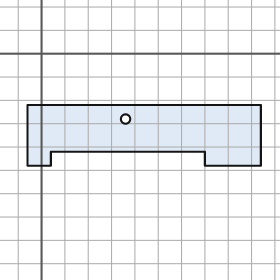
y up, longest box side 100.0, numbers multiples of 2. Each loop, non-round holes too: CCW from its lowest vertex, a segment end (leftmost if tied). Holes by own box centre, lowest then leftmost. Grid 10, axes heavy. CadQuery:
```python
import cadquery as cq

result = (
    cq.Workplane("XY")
    .moveTo(-6.0, -48.0)
    .lineTo(4.0, -48.0)
    .lineTo(4.0, -42.0)
    .lineTo(70.0, -42.0)
    .lineTo(70.0, -48.0)
    .lineTo(94.0, -48.0)
    .lineTo(94.0, -22.0)
    .lineTo(-6.0, -22.0)
    .close()
    .moveTo(36.0, -28.0)
    .circle(2.0)
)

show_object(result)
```